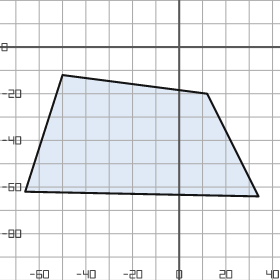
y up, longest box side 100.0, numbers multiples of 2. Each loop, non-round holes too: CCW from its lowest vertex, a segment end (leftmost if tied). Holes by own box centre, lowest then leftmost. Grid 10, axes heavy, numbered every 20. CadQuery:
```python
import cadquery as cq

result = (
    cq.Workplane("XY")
    .moveTo(34.0, -64.0)
    .lineTo(12.0, -20.0)
    .lineTo(-50.0, -12.0)
    .lineTo(-66.0, -62.0)
    .close()
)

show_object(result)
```